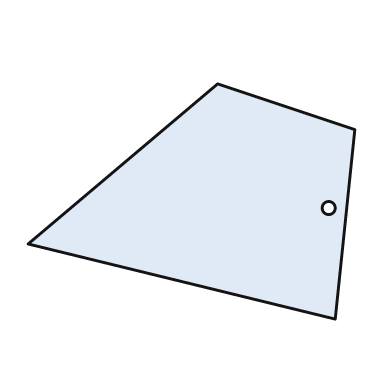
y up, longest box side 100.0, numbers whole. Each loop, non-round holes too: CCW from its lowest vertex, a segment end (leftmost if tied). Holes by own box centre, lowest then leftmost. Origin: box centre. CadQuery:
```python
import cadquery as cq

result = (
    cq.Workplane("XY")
    .moveTo(44.0, -36.0)
    .lineTo(50.0, 22.0)
    .lineTo(8.0, 36.0)
    .lineTo(-50.0, -13.0)
    .close()
    .moveTo(42.0, -2.0)
    .circle(2.0)
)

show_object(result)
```